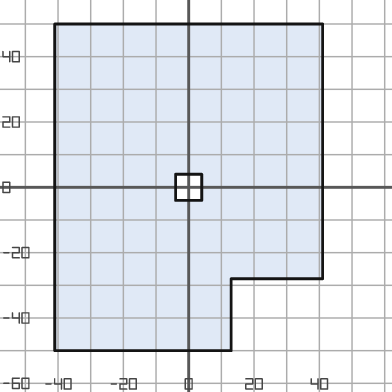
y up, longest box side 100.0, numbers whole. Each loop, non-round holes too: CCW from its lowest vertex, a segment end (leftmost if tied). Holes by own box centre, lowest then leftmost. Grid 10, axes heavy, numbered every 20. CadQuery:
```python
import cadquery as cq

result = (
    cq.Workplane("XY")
    .moveTo(-41.0, -50.0)
    .lineTo(13.0, -50.0)
    .lineTo(13.0, -28.0)
    .lineTo(41.0, -28.0)
    .lineTo(41.0, 50.0)
    .lineTo(-41.0, 50.0)
    .close()
    .moveTo(-4.0, -4.0)
    .lineTo(4.0, -4.0)
    .lineTo(4.0, 4.0)
    .lineTo(-4.0, 4.0)
    .close()
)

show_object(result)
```